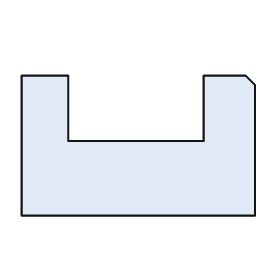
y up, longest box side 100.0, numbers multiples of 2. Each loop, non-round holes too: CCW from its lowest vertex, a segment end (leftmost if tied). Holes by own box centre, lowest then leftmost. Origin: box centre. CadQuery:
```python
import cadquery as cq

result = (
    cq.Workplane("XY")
    .moveTo(-50.0, -30.0)
    .lineTo(50.0, -30.0)
    .lineTo(50.0, 26.0)
    .lineTo(46.0, 30.0)
    .lineTo(28.0, 30.0)
    .lineTo(28.0, 2.0)
    .lineTo(-30.0, 2.0)
    .lineTo(-30.0, 30.0)
    .lineTo(-50.0, 30.0)
    .close()
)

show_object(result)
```